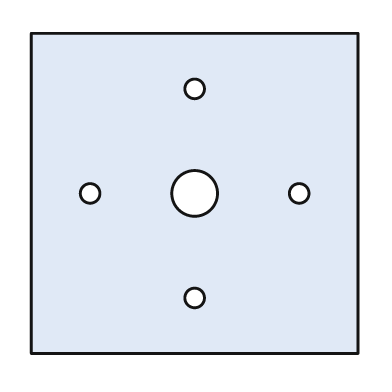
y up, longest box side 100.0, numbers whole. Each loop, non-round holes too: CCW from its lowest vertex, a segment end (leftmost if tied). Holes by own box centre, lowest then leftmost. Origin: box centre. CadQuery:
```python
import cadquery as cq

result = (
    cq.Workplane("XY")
    .moveTo(-50.0, -49.0)
    .lineTo(50.0, -49.0)
    .lineTo(50.0, 49.0)
    .lineTo(-50.0, 49.0)
    .close()
    .moveTo(0.0, -32.0)
    .circle(3.0)
    .moveTo(-32.0, 0.0)
    .circle(3.0)
    .moveTo(0.0, 0.0)
    .circle(7.0)
    .moveTo(32.0, 0.0)
    .circle(3.0)
    .moveTo(0.0, 32.0)
    .circle(3.0)
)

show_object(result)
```